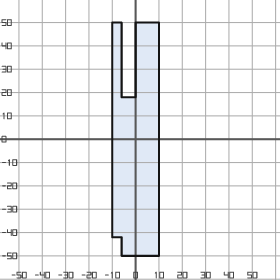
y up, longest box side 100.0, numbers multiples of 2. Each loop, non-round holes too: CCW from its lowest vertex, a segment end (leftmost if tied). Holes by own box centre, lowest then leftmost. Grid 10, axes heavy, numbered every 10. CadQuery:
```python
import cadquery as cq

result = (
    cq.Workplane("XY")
    .moveTo(-6.0, -50.0)
    .lineTo(10.0, -50.0)
    .lineTo(10.0, 50.0)
    .lineTo(0.0, 50.0)
    .lineTo(0.0, 18.0)
    .lineTo(-6.0, 18.0)
    .lineTo(-6.0, 50.0)
    .lineTo(-10.0, 50.0)
    .lineTo(-10.0, -42.0)
    .lineTo(-6.0, -42.0)
    .close()
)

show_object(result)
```